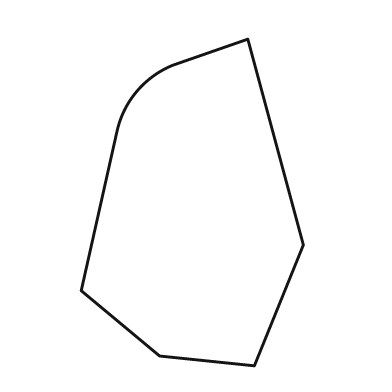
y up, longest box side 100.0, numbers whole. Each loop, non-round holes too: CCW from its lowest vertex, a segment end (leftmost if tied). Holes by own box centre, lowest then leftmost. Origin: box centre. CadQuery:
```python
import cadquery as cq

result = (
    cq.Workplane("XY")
    .moveTo(19.0, -50.0)
    .lineTo(34.0, -13.0)
    .lineTo(17.0, 50.0)
    .lineTo(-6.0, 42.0)
    .threePointArc((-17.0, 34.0), (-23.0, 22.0))
    .lineTo(-34.0, -27.0)
    .lineTo(-10.0, -47.0)
    .close()
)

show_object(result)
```